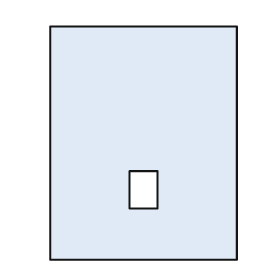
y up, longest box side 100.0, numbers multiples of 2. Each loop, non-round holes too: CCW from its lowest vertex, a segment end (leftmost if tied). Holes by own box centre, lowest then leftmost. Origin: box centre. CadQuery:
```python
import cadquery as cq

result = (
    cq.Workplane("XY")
    .moveTo(-40.0, -50.0)
    .lineTo(40.0, -50.0)
    .lineTo(40.0, 50.0)
    .lineTo(-40.0, 50.0)
    .close()
    .moveTo(-6.0, -28.0)
    .lineTo(6.0, -28.0)
    .lineTo(6.0, -12.0)
    .lineTo(-6.0, -12.0)
    .close()
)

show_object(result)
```